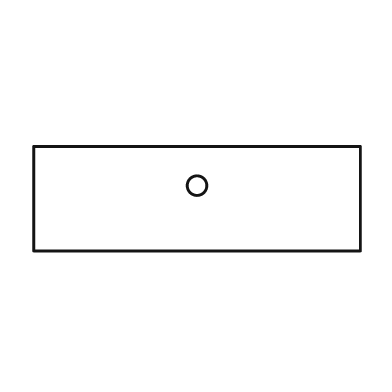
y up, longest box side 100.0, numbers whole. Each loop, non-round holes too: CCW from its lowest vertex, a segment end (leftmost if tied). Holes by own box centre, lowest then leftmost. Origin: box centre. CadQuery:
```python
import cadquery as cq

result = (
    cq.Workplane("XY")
    .moveTo(-50.0, -16.0)
    .lineTo(50.0, -16.0)
    .lineTo(50.0, 16.0)
    .lineTo(-50.0, 16.0)
    .close()
    .moveTo(0.0, 4.0)
    .circle(3.0)
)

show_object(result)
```